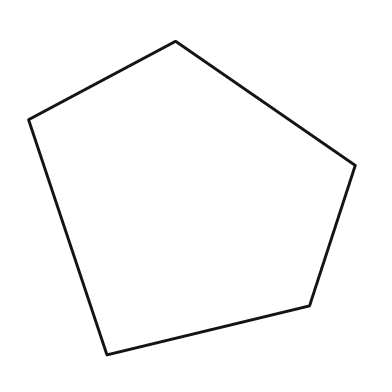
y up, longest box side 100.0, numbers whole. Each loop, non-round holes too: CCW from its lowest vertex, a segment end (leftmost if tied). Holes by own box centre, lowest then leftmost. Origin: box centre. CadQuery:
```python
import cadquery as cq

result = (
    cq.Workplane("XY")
    .moveTo(-26.0, -48.0)
    .lineTo(36.0, -33.0)
    .lineTo(50.0, 10.0)
    .lineTo(-5.0, 48.0)
    .lineTo(-50.0, 24.0)
    .close()
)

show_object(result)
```